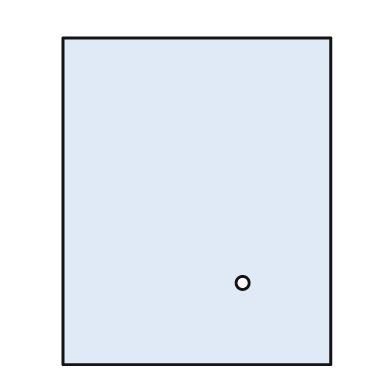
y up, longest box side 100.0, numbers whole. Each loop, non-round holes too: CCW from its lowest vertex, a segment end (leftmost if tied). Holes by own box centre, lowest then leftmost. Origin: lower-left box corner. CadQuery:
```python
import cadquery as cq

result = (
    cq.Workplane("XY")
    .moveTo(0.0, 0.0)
    .lineTo(82.0, 0.0)
    .lineTo(82.0, 100.0)
    .lineTo(0.0, 100.0)
    .close()
    .moveTo(55.0, 25.0)
    .circle(2.0)
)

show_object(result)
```